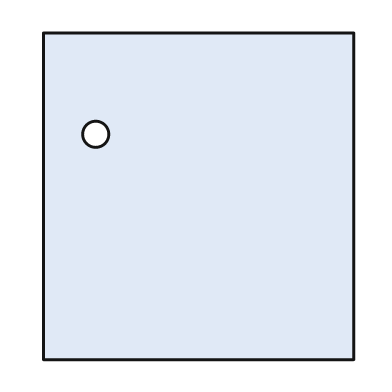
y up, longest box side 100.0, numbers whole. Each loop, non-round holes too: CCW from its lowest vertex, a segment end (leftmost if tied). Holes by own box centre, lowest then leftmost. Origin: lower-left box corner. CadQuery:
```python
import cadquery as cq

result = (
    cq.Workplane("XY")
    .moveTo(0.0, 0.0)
    .lineTo(95.0, 0.0)
    .lineTo(95.0, 100.0)
    .lineTo(0.0, 100.0)
    .close()
    .moveTo(16.0, 69.0)
    .circle(4.0)
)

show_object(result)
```